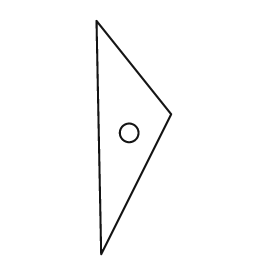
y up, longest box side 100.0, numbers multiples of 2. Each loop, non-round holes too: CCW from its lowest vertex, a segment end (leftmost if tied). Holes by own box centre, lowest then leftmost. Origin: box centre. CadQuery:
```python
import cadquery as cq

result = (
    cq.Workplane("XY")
    .moveTo(-14.0, -50.0)
    .lineTo(16.0, 10.0)
    .lineTo(-16.0, 50.0)
    .close()
    .moveTo(-2.0, 2.0)
    .circle(4.0)
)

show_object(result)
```